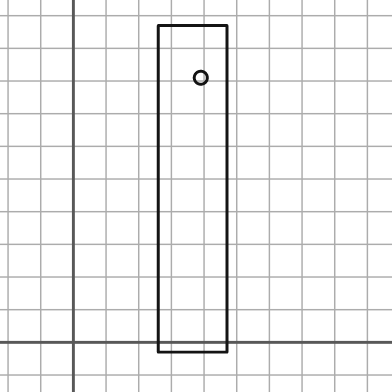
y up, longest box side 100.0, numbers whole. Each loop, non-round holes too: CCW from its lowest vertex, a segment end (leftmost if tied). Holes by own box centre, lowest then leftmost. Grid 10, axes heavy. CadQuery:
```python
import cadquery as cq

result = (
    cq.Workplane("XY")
    .moveTo(26.0, -3.0)
    .lineTo(47.0, -3.0)
    .lineTo(47.0, 97.0)
    .lineTo(26.0, 97.0)
    .close()
    .moveTo(39.0, 81.0)
    .circle(2.0)
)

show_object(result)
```